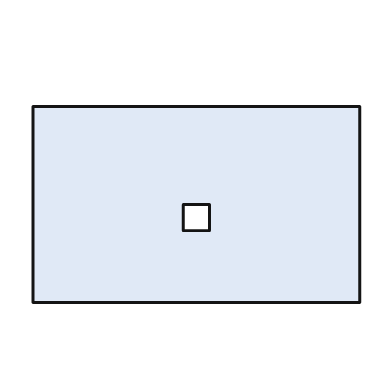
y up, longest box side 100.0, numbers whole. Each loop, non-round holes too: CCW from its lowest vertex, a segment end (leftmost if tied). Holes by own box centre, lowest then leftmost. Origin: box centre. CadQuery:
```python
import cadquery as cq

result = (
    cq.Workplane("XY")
    .moveTo(-50.0, -30.0)
    .lineTo(50.0, -30.0)
    .lineTo(50.0, 30.0)
    .lineTo(-50.0, 30.0)
    .close()
    .moveTo(-4.0, -8.0)
    .lineTo(4.0, -8.0)
    .lineTo(4.0, 0.0)
    .lineTo(-4.0, 0.0)
    .close()
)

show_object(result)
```